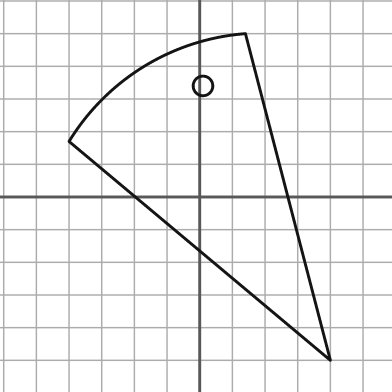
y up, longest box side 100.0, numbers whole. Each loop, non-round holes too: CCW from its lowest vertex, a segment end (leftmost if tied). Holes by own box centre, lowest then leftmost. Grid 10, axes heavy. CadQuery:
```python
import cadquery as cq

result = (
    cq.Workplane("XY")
    .moveTo(40.0, -50.0)
    .lineTo(14.0, 50.0)
    .threePointArc((-17.0, 40.0), (-40.0, 17.0))
    .close()
    .moveTo(1.0, 34.0)
    .circle(3.0)
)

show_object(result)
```